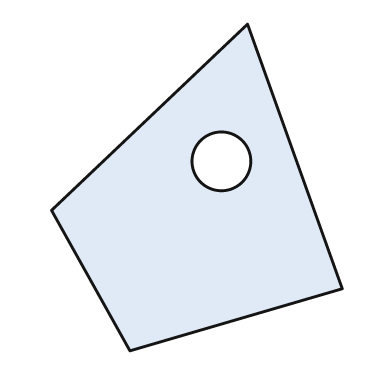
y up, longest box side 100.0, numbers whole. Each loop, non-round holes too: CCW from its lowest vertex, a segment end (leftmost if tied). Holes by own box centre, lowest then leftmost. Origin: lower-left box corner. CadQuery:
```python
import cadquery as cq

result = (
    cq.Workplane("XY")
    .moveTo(24.0, 0.0)
    .lineTo(89.0, 19.0)
    .lineTo(60.0, 100.0)
    .lineTo(0.0, 43.0)
    .close()
    .moveTo(52.0, 58.0)
    .circle(9.0)
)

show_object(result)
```